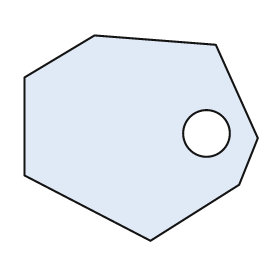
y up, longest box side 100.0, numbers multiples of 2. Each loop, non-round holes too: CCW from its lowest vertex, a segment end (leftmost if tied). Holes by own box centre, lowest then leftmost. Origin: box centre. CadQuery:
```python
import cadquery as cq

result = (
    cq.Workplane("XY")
    .moveTo(4.0, -44.0)
    .lineTo(42.0, -20.0)
    .lineTo(50.0, 0.0)
    .lineTo(32.0, 40.0)
    .lineTo(-20.0, 44.0)
    .lineTo(-50.0, 26.0)
    .lineTo(-50.0, -16.0)
    .close()
    .moveTo(28.0, 2.0)
    .circle(10.0)
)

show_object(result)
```